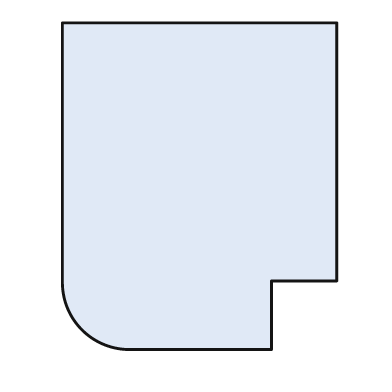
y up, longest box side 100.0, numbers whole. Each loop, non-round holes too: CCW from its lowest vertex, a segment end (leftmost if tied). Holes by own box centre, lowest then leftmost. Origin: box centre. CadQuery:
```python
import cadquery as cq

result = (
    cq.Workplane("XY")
    .moveTo(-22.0, -50.0)
    .lineTo(22.0, -50.0)
    .lineTo(22.0, -29.0)
    .lineTo(42.0, -29.0)
    .lineTo(42.0, 50.0)
    .lineTo(-42.0, 50.0)
    .lineTo(-42.0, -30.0)
    .threePointArc((-36.0, -44.0), (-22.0, -50.0))
    .close()
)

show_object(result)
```